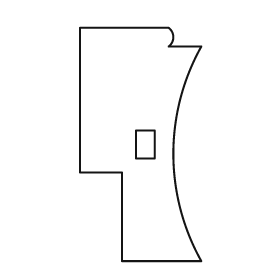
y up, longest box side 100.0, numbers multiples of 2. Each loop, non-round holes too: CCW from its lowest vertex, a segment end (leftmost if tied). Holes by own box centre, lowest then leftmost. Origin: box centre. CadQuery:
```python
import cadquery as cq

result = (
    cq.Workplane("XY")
    .moveTo(-8.0, -50.0)
    .lineTo(26.0, -50.0)
    .threePointArc((14.0, -4.0), (26.0, 42.0))
    .lineTo(12.0, 42.0)
    .threePointArc((14.0, 46.0), (12.0, 50.0))
    .lineTo(-26.0, 50.0)
    .lineTo(-26.0, -12.0)
    .lineTo(-8.0, -12.0)
    .close()
    .moveTo(-2.0, -6.0)
    .lineTo(6.0, -6.0)
    .lineTo(6.0, 6.0)
    .lineTo(-2.0, 6.0)
    .close()
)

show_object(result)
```